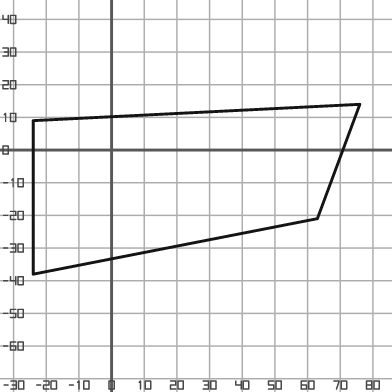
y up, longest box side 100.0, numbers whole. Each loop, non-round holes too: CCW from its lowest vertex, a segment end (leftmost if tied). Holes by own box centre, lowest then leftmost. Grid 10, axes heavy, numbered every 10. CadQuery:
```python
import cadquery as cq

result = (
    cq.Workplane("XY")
    .moveTo(-24.0, -38.0)
    .lineTo(63.0, -21.0)
    .lineTo(76.0, 14.0)
    .lineTo(-24.0, 9.0)
    .close()
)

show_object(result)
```